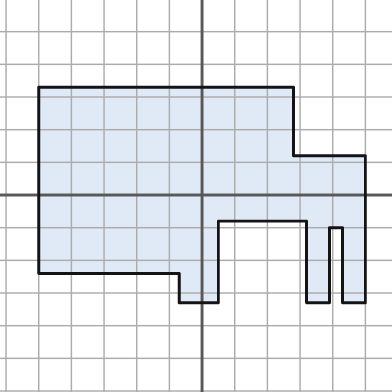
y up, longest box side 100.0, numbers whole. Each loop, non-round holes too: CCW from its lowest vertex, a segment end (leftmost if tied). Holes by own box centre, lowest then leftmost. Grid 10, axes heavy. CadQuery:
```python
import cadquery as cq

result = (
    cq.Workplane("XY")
    .moveTo(-7.0, -33.0)
    .lineTo(5.0, -33.0)
    .lineTo(5.0, -8.0)
    .lineTo(32.0, -8.0)
    .lineTo(32.0, -33.0)
    .lineTo(39.0, -33.0)
    .lineTo(39.0, -10.0)
    .lineTo(43.0, -10.0)
    .lineTo(43.0, -33.0)
    .lineTo(50.0, -33.0)
    .lineTo(50.0, 12.0)
    .lineTo(28.0, 12.0)
    .lineTo(28.0, 33.0)
    .lineTo(-50.0, 33.0)
    .lineTo(-50.0, -24.0)
    .lineTo(-7.0, -24.0)
    .close()
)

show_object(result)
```